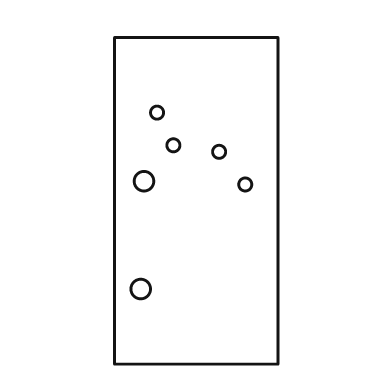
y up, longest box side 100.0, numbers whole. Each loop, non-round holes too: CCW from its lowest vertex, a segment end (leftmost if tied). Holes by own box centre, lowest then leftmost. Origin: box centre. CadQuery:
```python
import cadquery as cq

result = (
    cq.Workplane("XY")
    .moveTo(-25.0, -50.0)
    .lineTo(25.0, -50.0)
    .lineTo(25.0, 50.0)
    .lineTo(-25.0, 50.0)
    .close()
    .moveTo(-17.0, -27.0)
    .circle(3.0)
    .moveTo(15.0, 5.0)
    .circle(2.0)
    .moveTo(-16.0, 6.0)
    .circle(3.0)
    .moveTo(7.0, 15.0)
    .circle(2.0)
    .moveTo(-7.0, 17.0)
    .circle(2.0)
    .moveTo(-12.0, 27.0)
    .circle(2.0)
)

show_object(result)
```